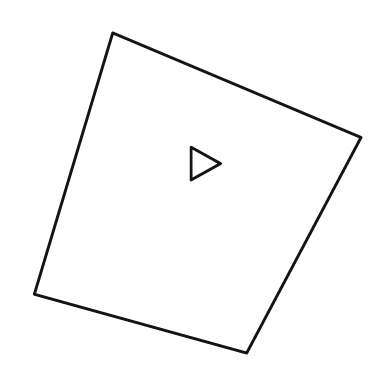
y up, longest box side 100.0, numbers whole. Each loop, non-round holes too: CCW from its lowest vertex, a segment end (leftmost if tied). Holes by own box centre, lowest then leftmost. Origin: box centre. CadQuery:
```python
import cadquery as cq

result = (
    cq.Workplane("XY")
    .moveTo(15.0, -49.0)
    .lineTo(50.0, 17.0)
    .lineTo(-26.0, 49.0)
    .lineTo(-50.0, -31.0)
    .close()
    .moveTo(-2.0, 4.0)
    .lineTo(7.0, 9.0)
    .lineTo(-2.0, 14.0)
    .close()
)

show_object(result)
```